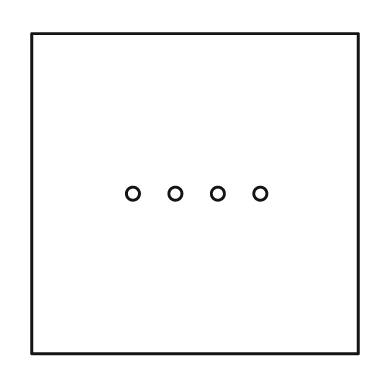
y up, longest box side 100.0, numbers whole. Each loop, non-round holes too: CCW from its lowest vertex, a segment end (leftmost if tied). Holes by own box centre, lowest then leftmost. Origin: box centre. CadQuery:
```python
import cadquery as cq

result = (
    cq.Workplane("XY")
    .moveTo(-50.0, -49.0)
    .lineTo(50.0, -49.0)
    .lineTo(50.0, 49.0)
    .lineTo(-50.0, 49.0)
    .close()
    .moveTo(-19.0, 0.0)
    .circle(2.0)
    .moveTo(-6.0, 0.0)
    .circle(2.0)
    .moveTo(7.0, 0.0)
    .circle(2.0)
    .moveTo(20.0, 0.0)
    .circle(2.0)
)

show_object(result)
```